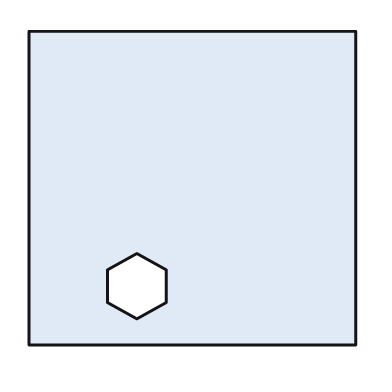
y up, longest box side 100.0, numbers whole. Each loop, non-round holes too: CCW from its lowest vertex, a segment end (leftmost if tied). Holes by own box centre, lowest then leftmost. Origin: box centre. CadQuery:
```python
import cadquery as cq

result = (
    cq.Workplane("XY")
    .moveTo(-50.0, -48.0)
    .lineTo(50.0, -48.0)
    .lineTo(50.0, 48.0)
    .lineTo(-50.0, 48.0)
    .close()
    .moveTo(-17.0, -40.0)
    .lineTo(-8.0, -35.0)
    .lineTo(-8.0, -25.0)
    .lineTo(-17.0, -20.0)
    .lineTo(-26.0, -25.0)
    .lineTo(-26.0, -35.0)
    .close()
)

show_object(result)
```